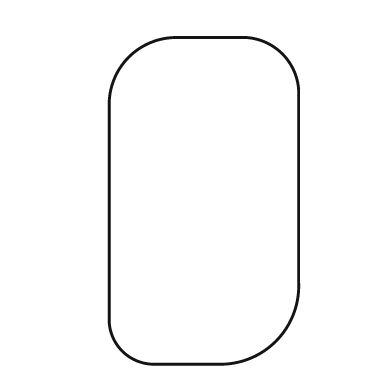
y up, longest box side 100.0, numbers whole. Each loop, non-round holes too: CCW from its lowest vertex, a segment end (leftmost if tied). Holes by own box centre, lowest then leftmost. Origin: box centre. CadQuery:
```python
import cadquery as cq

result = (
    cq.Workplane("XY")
    .moveTo(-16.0, -50.0)
    .lineTo(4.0, -50.0)
    .threePointArc((22.0, -43.0), (29.0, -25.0))
    .lineTo(29.0, 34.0)
    .threePointArc((24.0, 45.0), (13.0, 50.0))
    .lineTo(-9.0, 50.0)
    .threePointArc((-23.0, 44.0), (-29.0, 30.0))
    .lineTo(-29.0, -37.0)
    .threePointArc((-25.0, -46.0), (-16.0, -50.0))
    .close()
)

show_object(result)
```